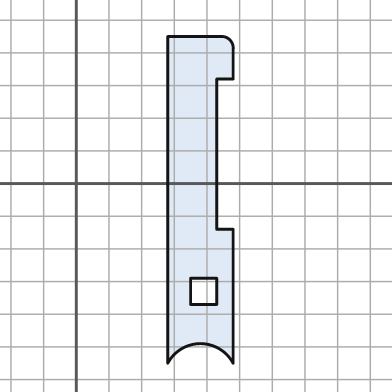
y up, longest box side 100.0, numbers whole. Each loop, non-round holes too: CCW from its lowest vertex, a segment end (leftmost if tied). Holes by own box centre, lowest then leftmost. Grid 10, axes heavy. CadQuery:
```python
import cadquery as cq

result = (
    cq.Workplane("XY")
    .moveTo(28.0, -55.0)
    .threePointArc((38.0, -49.0), (48.0, -55.0))
    .lineTo(48.0, -14.0)
    .lineTo(43.0, -14.0)
    .lineTo(43.0, 32.0)
    .lineTo(48.0, 32.0)
    .lineTo(48.0, 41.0)
    .threePointArc((47.0, 44.0), (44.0, 45.0))
    .lineTo(28.0, 45.0)
    .close()
    .moveTo(35.0, -37.0)
    .lineTo(43.0, -37.0)
    .lineTo(43.0, -29.0)
    .lineTo(35.0, -29.0)
    .close()
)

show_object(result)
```